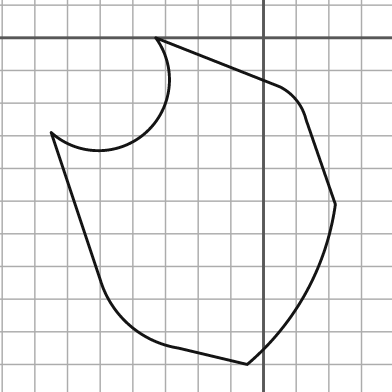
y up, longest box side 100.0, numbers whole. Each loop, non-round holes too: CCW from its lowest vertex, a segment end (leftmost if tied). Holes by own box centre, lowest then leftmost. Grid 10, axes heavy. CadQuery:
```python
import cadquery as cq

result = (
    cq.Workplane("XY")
    .moveTo(-5.0, -100.0)
    .threePointArc((13.0, -78.0), (22.0, -51.0))
    .lineTo(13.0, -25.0)
    .threePointArc((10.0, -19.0), (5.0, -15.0))
    .lineTo(-33.0, 0.0)
    .threePointArc((-36.0, -29.0), (-65.0, -29.0))
    .lineTo(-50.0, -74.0)
    .threePointArc((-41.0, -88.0), (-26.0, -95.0))
    .close()
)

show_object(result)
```